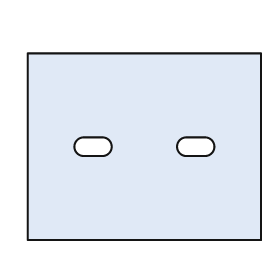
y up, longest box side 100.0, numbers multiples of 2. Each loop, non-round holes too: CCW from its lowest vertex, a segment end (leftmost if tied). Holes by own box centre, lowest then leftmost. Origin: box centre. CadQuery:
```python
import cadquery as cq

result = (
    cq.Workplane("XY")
    .moveTo(-50.0, -40.0)
    .lineTo(50.0, -40.0)
    .lineTo(50.0, 40.0)
    .lineTo(-50.0, 40.0)
    .close()
    .moveTo(-26.0, -4.0)
    .lineTo(-18.0, -4.0)
    .threePointArc((-14.0, 0.0), (-18.0, 4.0))
    .lineTo(-26.0, 4.0)
    .threePointArc((-30.0, 0.0), (-26.0, -4.0))
    .close()
    .moveTo(18.0, -4.0)
    .lineTo(26.0, -4.0)
    .threePointArc((30.0, 0.0), (26.0, 4.0))
    .lineTo(18.0, 4.0)
    .threePointArc((14.0, 0.0), (18.0, -4.0))
    .close()
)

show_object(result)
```